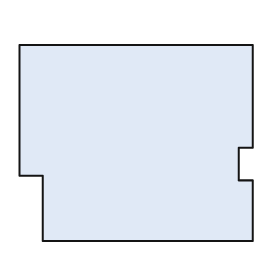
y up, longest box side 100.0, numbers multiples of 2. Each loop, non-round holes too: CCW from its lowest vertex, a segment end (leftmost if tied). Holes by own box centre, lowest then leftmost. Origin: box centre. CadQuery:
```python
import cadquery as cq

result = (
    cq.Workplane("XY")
    .moveTo(-40.0, -42.0)
    .lineTo(50.0, -42.0)
    .lineTo(50.0, -16.0)
    .lineTo(44.0, -16.0)
    .lineTo(44.0, -2.0)
    .lineTo(50.0, -2.0)
    .lineTo(50.0, 42.0)
    .lineTo(-50.0, 42.0)
    .lineTo(-50.0, -14.0)
    .lineTo(-40.0, -14.0)
    .close()
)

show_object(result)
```